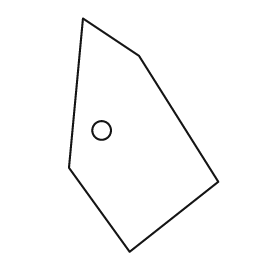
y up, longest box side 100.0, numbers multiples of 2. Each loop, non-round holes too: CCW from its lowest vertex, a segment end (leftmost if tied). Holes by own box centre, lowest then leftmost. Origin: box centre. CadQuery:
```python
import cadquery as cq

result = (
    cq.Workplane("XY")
    .moveTo(-6.0, -50.0)
    .lineTo(32.0, -20.0)
    .lineTo(-2.0, 34.0)
    .lineTo(-26.0, 50.0)
    .lineTo(-32.0, -14.0)
    .close()
    .moveTo(-18.0, 2.0)
    .circle(4.0)
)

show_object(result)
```